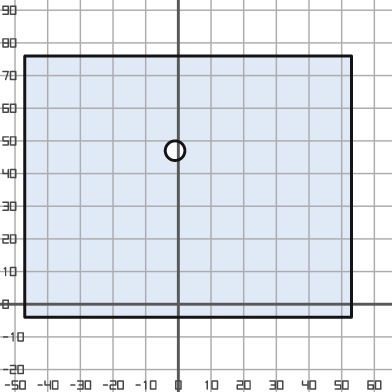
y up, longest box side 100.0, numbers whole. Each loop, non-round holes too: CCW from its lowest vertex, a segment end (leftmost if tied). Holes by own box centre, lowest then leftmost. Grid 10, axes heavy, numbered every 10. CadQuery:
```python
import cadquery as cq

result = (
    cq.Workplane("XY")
    .moveTo(-47.0, -4.0)
    .lineTo(53.0, -4.0)
    .lineTo(53.0, 76.0)
    .lineTo(-47.0, 76.0)
    .close()
    .moveTo(-1.0, 47.0)
    .circle(3.0)
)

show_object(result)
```